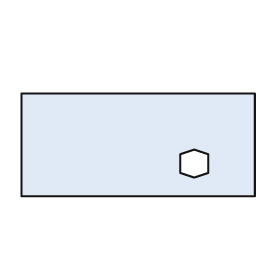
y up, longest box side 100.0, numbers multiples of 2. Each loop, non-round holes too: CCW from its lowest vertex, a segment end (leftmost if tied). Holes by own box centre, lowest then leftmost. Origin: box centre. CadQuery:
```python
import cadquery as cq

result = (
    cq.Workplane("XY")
    .moveTo(-50.0, -22.0)
    .lineTo(50.0, -22.0)
    .lineTo(50.0, 22.0)
    .lineTo(-50.0, 22.0)
    .close()
    .moveTo(24.0, -14.0)
    .lineTo(30.0, -12.0)
    .lineTo(30.0, -4.0)
    .lineTo(24.0, -2.0)
    .lineTo(18.0, -4.0)
    .lineTo(18.0, -12.0)
    .close()
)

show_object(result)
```